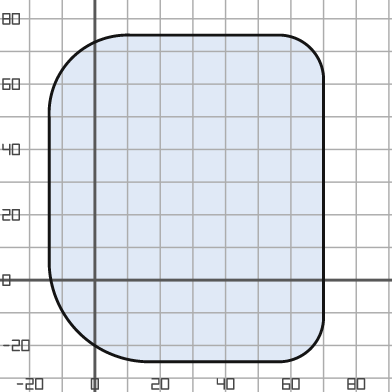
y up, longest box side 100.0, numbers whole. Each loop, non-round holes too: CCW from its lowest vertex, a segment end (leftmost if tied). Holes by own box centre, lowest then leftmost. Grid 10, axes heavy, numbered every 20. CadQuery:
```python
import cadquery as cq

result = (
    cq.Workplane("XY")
    .moveTo(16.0, -25.0)
    .lineTo(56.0, -25.0)
    .threePointArc((66.0, -21.0), (70.0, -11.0))
    .lineTo(70.0, 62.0)
    .threePointArc((66.0, 71.0), (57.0, 75.0))
    .lineTo(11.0, 75.0)
    .threePointArc((-7.0, 68.0), (-14.0, 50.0))
    .lineTo(-14.0, 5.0)
    .threePointArc((-5.0, -16.0), (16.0, -25.0))
    .close()
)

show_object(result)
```